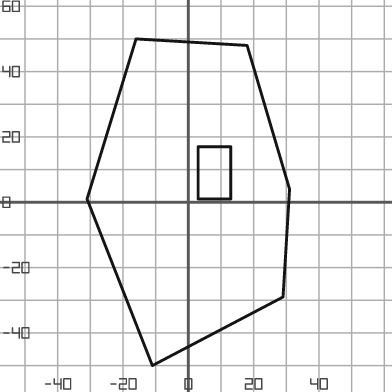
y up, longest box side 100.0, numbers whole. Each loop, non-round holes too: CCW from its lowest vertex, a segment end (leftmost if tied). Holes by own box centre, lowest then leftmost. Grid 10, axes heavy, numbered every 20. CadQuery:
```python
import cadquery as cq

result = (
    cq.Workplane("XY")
    .moveTo(-11.0, -50.0)
    .lineTo(29.0, -29.0)
    .lineTo(31.0, 4.0)
    .lineTo(18.0, 48.0)
    .lineTo(-16.0, 50.0)
    .lineTo(-31.0, 1.0)
    .close()
    .moveTo(3.0, 1.0)
    .lineTo(13.0, 1.0)
    .lineTo(13.0, 17.0)
    .lineTo(3.0, 17.0)
    .close()
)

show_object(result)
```